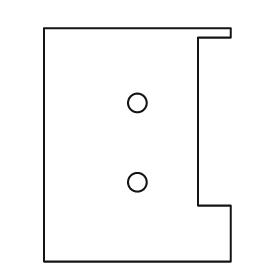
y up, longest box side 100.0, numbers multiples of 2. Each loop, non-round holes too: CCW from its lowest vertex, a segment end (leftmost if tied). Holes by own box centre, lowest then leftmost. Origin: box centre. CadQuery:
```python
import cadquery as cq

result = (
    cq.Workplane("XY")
    .moveTo(-40.0, -50.0)
    .lineTo(40.0, -50.0)
    .lineTo(40.0, -26.0)
    .lineTo(26.0, -26.0)
    .lineTo(26.0, 46.0)
    .lineTo(40.0, 46.0)
    .lineTo(40.0, 50.0)
    .lineTo(-40.0, 50.0)
    .close()
    .moveTo(0.0, -16.0)
    .circle(4.0)
    .moveTo(0.0, 18.0)
    .circle(4.0)
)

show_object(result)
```